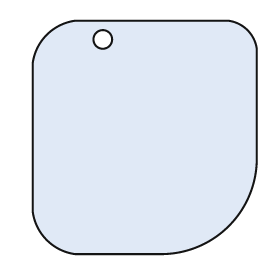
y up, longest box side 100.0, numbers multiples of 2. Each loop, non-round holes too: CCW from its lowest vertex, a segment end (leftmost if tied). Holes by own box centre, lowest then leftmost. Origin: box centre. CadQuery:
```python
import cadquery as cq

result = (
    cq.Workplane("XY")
    .moveTo(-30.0, -50.0)
    .lineTo(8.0, -50.0)
    .threePointArc((36.0, -38.0), (48.0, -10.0))
    .lineTo(48.0, 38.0)
    .threePointArc((44.0, 46.0), (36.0, 50.0))
    .lineTo(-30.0, 50.0)
    .threePointArc((-42.0, 44.0), (-48.0, 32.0))
    .lineTo(-48.0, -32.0)
    .threePointArc((-42.0, -44.0), (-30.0, -50.0))
    .close()
    .moveTo(-18.0, 42.0)
    .circle(4.0)
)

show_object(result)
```